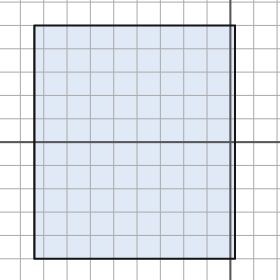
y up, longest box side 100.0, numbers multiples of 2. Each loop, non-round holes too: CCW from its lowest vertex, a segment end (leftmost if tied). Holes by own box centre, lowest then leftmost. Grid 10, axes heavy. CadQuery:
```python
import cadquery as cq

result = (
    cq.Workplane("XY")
    .moveTo(-84.0, -50.0)
    .lineTo(2.0, -50.0)
    .lineTo(2.0, 50.0)
    .lineTo(-84.0, 50.0)
    .close()
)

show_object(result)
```